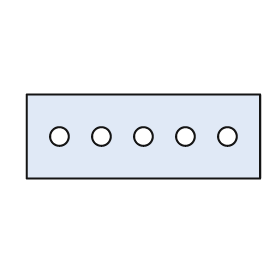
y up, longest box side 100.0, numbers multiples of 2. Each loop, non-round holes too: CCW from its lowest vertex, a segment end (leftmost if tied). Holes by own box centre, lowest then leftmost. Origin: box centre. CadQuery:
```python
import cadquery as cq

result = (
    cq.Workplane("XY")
    .moveTo(-50.0, -18.0)
    .lineTo(50.0, -18.0)
    .lineTo(50.0, 18.0)
    .lineTo(-50.0, 18.0)
    .close()
    .moveTo(-36.0, 0.0)
    .circle(4.0)
    .moveTo(-18.0, 0.0)
    .circle(4.0)
    .moveTo(0.0, 0.0)
    .circle(4.0)
    .moveTo(18.0, 0.0)
    .circle(4.0)
    .moveTo(36.0, 0.0)
    .circle(4.0)
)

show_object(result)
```